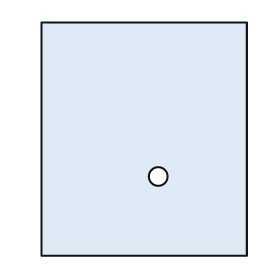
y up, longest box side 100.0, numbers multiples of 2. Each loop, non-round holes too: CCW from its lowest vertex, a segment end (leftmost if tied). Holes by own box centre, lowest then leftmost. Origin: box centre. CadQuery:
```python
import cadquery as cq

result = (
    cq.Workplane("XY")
    .moveTo(-44.0, -50.0)
    .lineTo(44.0, -50.0)
    .lineTo(44.0, 50.0)
    .lineTo(-44.0, 50.0)
    .close()
    .moveTo(6.0, -16.0)
    .circle(4.0)
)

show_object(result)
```